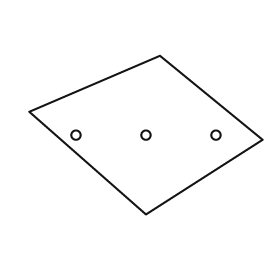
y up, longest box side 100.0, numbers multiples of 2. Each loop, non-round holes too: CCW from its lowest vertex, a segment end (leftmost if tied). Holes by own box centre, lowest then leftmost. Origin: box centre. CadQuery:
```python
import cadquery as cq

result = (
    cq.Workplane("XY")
    .moveTo(0.0, -34.0)
    .lineTo(50.0, -2.0)
    .lineTo(6.0, 34.0)
    .lineTo(-50.0, 10.0)
    .close()
    .moveTo(-30.0, 0.0)
    .circle(2.0)
    .moveTo(0.0, 0.0)
    .circle(2.0)
    .moveTo(30.0, 0.0)
    .circle(2.0)
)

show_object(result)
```